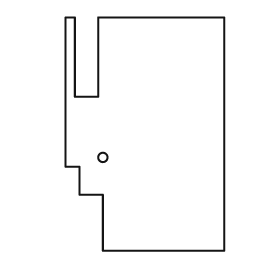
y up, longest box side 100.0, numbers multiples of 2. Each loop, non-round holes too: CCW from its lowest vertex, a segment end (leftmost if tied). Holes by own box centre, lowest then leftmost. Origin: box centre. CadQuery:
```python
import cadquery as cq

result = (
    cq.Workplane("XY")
    .moveTo(-18.0, -50.0)
    .lineTo(34.0, -50.0)
    .lineTo(34.0, 50.0)
    .lineTo(-20.0, 50.0)
    .lineTo(-20.0, 16.0)
    .lineTo(-30.0, 16.0)
    .lineTo(-30.0, 50.0)
    .lineTo(-34.0, 50.0)
    .lineTo(-34.0, -14.0)
    .lineTo(-28.0, -14.0)
    .lineTo(-28.0, -26.0)
    .lineTo(-18.0, -26.0)
    .close()
    .moveTo(-18.0, -10.0)
    .circle(2.0)
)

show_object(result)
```